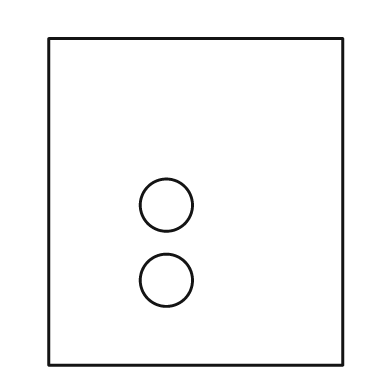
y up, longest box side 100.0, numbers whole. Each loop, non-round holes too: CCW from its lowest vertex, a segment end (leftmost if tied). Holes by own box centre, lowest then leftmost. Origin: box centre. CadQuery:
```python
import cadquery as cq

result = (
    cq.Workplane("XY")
    .moveTo(-45.0, -50.0)
    .lineTo(45.0, -50.0)
    .lineTo(45.0, 50.0)
    .lineTo(-45.0, 50.0)
    .close()
    .moveTo(-9.0, -24.0)
    .circle(8.0)
    .moveTo(-9.0, -1.0)
    .circle(8.0)
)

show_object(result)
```